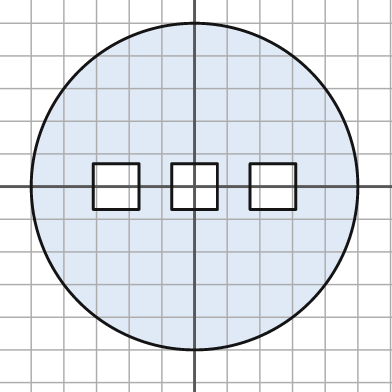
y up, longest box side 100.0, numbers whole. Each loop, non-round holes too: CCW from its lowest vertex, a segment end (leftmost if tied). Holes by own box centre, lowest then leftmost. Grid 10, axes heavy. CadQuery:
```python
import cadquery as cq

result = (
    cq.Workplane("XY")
    .moveTo(0.0, 0.0)
    .circle(50.0)
    .moveTo(-31.0, -7.0)
    .lineTo(-17.0, -7.0)
    .lineTo(-17.0, 7.0)
    .lineTo(-31.0, 7.0)
    .close()
    .moveTo(-7.0, -7.0)
    .lineTo(7.0, -7.0)
    .lineTo(7.0, 7.0)
    .lineTo(-7.0, 7.0)
    .close()
    .moveTo(17.0, -7.0)
    .lineTo(31.0, -7.0)
    .lineTo(31.0, 7.0)
    .lineTo(17.0, 7.0)
    .close()
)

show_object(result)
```